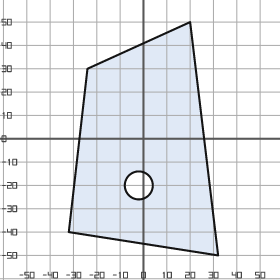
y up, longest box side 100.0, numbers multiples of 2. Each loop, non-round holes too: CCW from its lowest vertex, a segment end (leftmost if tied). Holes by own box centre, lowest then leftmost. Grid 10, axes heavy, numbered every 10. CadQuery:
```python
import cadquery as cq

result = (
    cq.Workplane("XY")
    .moveTo(32.0, -50.0)
    .lineTo(20.0, 50.0)
    .lineTo(-24.0, 30.0)
    .lineTo(-32.0, -40.0)
    .close()
    .moveTo(-2.0, -20.0)
    .circle(6.0)
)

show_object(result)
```